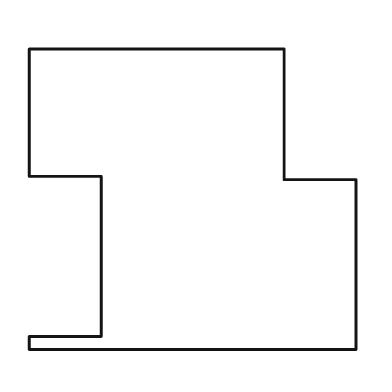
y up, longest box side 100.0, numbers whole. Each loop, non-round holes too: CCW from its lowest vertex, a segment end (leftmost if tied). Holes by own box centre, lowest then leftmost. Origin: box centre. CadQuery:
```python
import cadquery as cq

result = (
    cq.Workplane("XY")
    .moveTo(-50.0, -46.0)
    .lineTo(50.0, -46.0)
    .lineTo(50.0, 6.0)
    .lineTo(28.0, 6.0)
    .lineTo(28.0, 46.0)
    .lineTo(-50.0, 46.0)
    .lineTo(-50.0, 7.0)
    .lineTo(-28.0, 7.0)
    .lineTo(-28.0, -42.0)
    .lineTo(-50.0, -42.0)
    .close()
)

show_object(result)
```